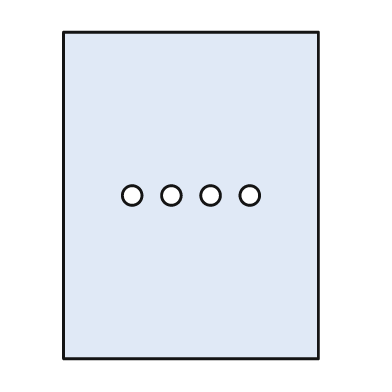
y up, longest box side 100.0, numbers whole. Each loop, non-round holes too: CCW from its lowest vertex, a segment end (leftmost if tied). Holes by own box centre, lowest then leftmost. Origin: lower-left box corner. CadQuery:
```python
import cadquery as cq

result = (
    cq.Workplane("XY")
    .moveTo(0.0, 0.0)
    .lineTo(78.0, 0.0)
    .lineTo(78.0, 100.0)
    .lineTo(0.0, 100.0)
    .close()
    .moveTo(21.0, 50.0)
    .circle(3.0)
    .moveTo(33.0, 50.0)
    .circle(3.0)
    .moveTo(45.0, 50.0)
    .circle(3.0)
    .moveTo(57.0, 50.0)
    .circle(3.0)
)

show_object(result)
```